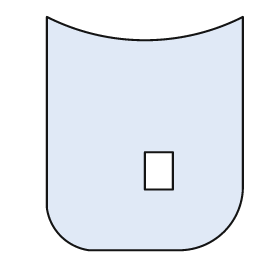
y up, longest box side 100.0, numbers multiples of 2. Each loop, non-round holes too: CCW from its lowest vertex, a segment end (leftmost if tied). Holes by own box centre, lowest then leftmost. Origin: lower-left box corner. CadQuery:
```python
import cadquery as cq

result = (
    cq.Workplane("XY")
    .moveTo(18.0, 0.0)
    .lineTo(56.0, 0.0)
    .threePointArc((76.0, 8.0), (84.0, 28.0))
    .lineTo(84.0, 100.0)
    .threePointArc((42.0, 90.0), (0.0, 100.0))
    .lineTo(0.0, 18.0)
    .threePointArc((6.0, 6.0), (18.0, 0.0))
    .close()
    .moveTo(42.0, 26.0)
    .lineTo(54.0, 26.0)
    .lineTo(54.0, 42.0)
    .lineTo(42.0, 42.0)
    .close()
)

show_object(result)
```